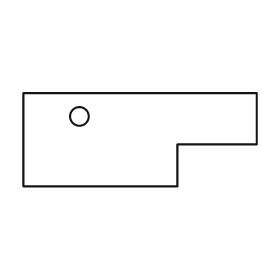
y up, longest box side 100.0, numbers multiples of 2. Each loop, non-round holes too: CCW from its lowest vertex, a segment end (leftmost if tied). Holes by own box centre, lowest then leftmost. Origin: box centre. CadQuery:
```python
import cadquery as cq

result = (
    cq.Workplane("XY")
    .moveTo(-50.0, -20.0)
    .lineTo(16.0, -20.0)
    .lineTo(16.0, -2.0)
    .lineTo(50.0, -2.0)
    .lineTo(50.0, 20.0)
    .lineTo(-50.0, 20.0)
    .close()
    .moveTo(-26.0, 10.0)
    .circle(4.0)
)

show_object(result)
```